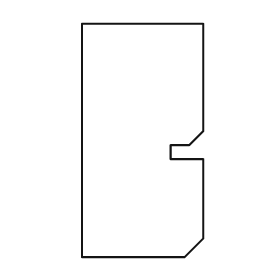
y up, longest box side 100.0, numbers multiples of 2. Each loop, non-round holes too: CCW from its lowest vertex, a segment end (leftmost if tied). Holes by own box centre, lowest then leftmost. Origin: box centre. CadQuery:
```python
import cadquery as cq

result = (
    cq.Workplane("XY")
    .moveTo(-26.0, -50.0)
    .lineTo(18.0, -50.0)
    .lineTo(26.0, -42.0)
    .lineTo(26.0, -8.0)
    .lineTo(12.0, -8.0)
    .lineTo(12.0, -2.0)
    .lineTo(20.0, -2.0)
    .lineTo(26.0, 4.0)
    .lineTo(26.0, 50.0)
    .lineTo(-26.0, 50.0)
    .close()
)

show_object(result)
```